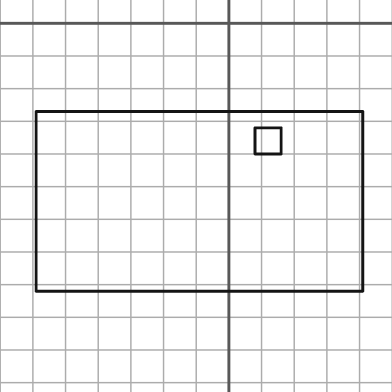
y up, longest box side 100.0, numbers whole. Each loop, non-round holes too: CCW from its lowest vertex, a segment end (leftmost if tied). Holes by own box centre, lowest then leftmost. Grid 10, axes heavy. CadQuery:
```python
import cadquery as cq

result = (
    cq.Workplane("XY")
    .moveTo(-59.0, -82.0)
    .lineTo(41.0, -82.0)
    .lineTo(41.0, -27.0)
    .lineTo(-59.0, -27.0)
    .close()
    .moveTo(8.0, -40.0)
    .lineTo(16.0, -40.0)
    .lineTo(16.0, -32.0)
    .lineTo(8.0, -32.0)
    .close()
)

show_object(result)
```